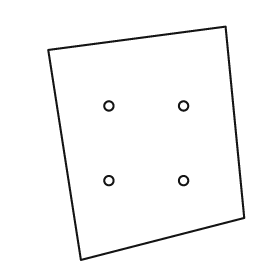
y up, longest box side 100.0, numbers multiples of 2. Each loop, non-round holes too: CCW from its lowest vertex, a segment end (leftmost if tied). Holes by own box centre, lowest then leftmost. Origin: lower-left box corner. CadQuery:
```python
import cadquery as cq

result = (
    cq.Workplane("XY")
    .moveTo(14.0, 0.0)
    .lineTo(84.0, 18.0)
    .lineTo(76.0, 100.0)
    .lineTo(0.0, 90.0)
    .close()
    .moveTo(26.0, 34.0)
    .circle(2.0)
    .moveTo(58.0, 34.0)
    .circle(2.0)
    .moveTo(26.0, 66.0)
    .circle(2.0)
    .moveTo(58.0, 66.0)
    .circle(2.0)
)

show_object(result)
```